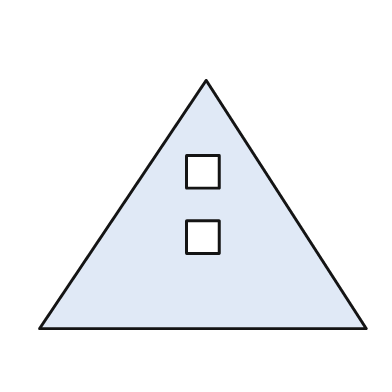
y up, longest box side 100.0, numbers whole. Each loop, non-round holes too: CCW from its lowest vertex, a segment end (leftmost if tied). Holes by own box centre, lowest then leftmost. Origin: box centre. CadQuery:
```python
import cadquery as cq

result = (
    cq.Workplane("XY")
    .moveTo(-50.0, -38.0)
    .lineTo(50.0, -38.0)
    .lineTo(1.0, 38.0)
    .close()
    .moveTo(-5.0, -15.0)
    .lineTo(5.0, -15.0)
    .lineTo(5.0, -5.0)
    .lineTo(-5.0, -5.0)
    .close()
    .moveTo(-5.0, 5.0)
    .lineTo(5.0, 5.0)
    .lineTo(5.0, 15.0)
    .lineTo(-5.0, 15.0)
    .close()
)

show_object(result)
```